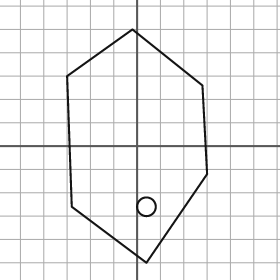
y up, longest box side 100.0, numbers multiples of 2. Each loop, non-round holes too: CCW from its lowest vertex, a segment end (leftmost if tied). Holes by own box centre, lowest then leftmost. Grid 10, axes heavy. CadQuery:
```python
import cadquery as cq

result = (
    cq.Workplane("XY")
    .moveTo(4.0, -50.0)
    .lineTo(30.0, -12.0)
    .lineTo(28.0, 26.0)
    .lineTo(-2.0, 50.0)
    .lineTo(-30.0, 30.0)
    .lineTo(-28.0, -26.0)
    .close()
    .moveTo(4.0, -26.0)
    .circle(4.0)
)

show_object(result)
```